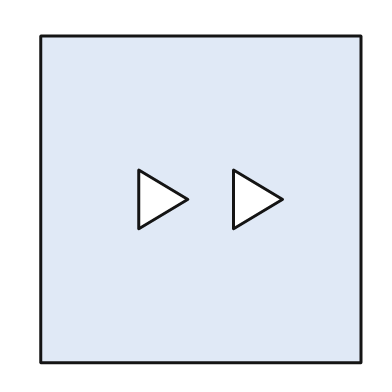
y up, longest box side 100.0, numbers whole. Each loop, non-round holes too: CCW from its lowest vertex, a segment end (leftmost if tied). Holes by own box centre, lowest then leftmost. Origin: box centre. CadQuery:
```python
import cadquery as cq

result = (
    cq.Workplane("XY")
    .moveTo(-49.0, -50.0)
    .lineTo(49.0, -50.0)
    .lineTo(49.0, 50.0)
    .lineTo(-49.0, 50.0)
    .close()
    .moveTo(-19.0, -9.0)
    .lineTo(-4.0, 0.0)
    .lineTo(-19.0, 9.0)
    .close()
    .moveTo(10.0, -9.0)
    .lineTo(25.0, 0.0)
    .lineTo(10.0, 9.0)
    .close()
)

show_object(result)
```